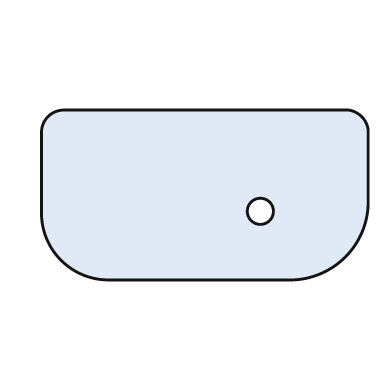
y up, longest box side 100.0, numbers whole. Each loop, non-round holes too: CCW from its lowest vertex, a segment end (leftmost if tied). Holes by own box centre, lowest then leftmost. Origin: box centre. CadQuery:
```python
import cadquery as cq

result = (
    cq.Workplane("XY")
    .moveTo(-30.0, -26.0)
    .lineTo(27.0, -26.0)
    .threePointArc((43.0, -19.0), (50.0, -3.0))
    .lineTo(50.0, 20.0)
    .threePointArc((48.0, 24.0), (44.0, 26.0))
    .lineTo(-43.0, 26.0)
    .threePointArc((-48.0, 24.0), (-50.0, 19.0))
    .lineTo(-50.0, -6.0)
    .threePointArc((-44.0, -20.0), (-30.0, -26.0))
    .close()
    .moveTo(17.0, -5.0)
    .circle(4.0)
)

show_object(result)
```